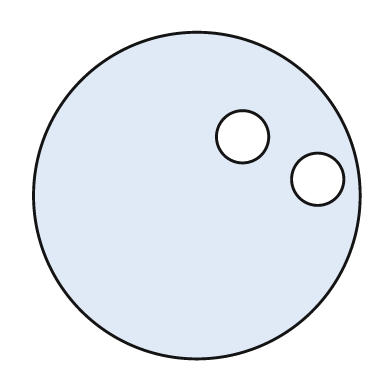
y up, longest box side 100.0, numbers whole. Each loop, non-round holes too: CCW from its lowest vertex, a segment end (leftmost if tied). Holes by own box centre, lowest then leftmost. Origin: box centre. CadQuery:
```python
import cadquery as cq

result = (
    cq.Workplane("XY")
    .moveTo(0.0, 0.0)
    .circle(50.0)
    .moveTo(37.0, 5.0)
    .circle(8.0)
    .moveTo(14.0, 18.0)
    .circle(8.0)
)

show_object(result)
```